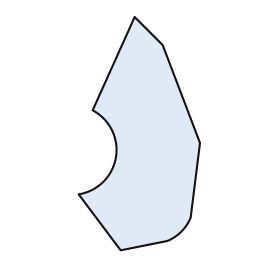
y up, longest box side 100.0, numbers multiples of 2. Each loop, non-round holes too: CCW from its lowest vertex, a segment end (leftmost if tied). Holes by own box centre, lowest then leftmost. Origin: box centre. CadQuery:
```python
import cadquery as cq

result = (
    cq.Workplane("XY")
    .moveTo(-8.0, -50.0)
    .lineTo(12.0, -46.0)
    .threePointArc((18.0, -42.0), (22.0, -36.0))
    .lineTo(26.0, -4.0)
    .lineTo(10.0, 38.0)
    .lineTo(-2.0, 50.0)
    .lineTo(-20.0, 10.0)
    .threePointArc((-10.0, -10.0), (-26.0, -26.0))
    .close()
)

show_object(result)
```